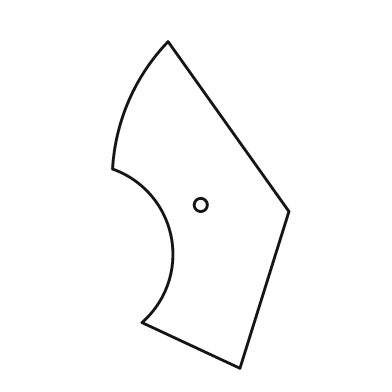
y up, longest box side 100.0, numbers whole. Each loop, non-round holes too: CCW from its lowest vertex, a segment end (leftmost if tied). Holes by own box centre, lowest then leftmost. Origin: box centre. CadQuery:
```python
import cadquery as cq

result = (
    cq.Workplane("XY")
    .moveTo(12.0, -50.0)
    .lineTo(27.0, -2.0)
    .lineTo(-10.0, 50.0)
    .threePointArc((-22.0, 32.0), (-27.0, 11.0))
    .threePointArc((-9.0, -10.0), (-18.0, -36.0))
    .close()
    .moveTo(0.0, 0.0)
    .circle(2.0)
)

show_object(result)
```